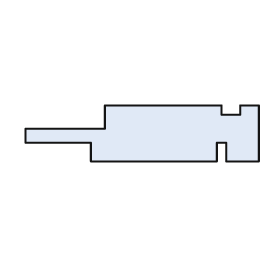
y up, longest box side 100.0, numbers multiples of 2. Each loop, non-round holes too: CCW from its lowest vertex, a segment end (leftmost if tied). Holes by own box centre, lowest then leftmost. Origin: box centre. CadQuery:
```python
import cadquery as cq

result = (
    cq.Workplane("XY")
    .moveTo(-22.0, -12.0)
    .lineTo(32.0, -12.0)
    .lineTo(32.0, -4.0)
    .lineTo(36.0, -4.0)
    .lineTo(36.0, -12.0)
    .lineTo(50.0, -12.0)
    .lineTo(50.0, 12.0)
    .lineTo(42.0, 12.0)
    .lineTo(42.0, 8.0)
    .lineTo(34.0, 8.0)
    .lineTo(34.0, 12.0)
    .lineTo(-16.0, 12.0)
    .lineTo(-16.0, 2.0)
    .lineTo(-50.0, 2.0)
    .lineTo(-50.0, -4.0)
    .lineTo(-22.0, -4.0)
    .close()
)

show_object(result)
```